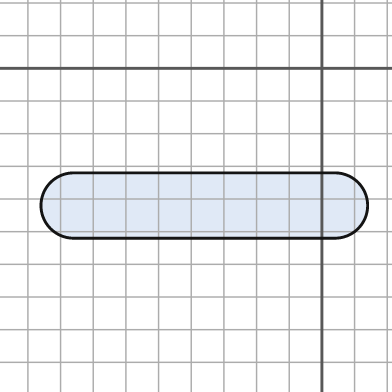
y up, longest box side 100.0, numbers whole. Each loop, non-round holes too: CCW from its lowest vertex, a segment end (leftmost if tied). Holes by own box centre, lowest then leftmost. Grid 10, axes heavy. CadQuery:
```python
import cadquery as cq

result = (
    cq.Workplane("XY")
    .moveTo(-76.0, -52.0)
    .lineTo(4.0, -52.0)
    .threePointArc((14.0, -42.0), (4.0, -32.0))
    .lineTo(-76.0, -32.0)
    .threePointArc((-86.0, -42.0), (-76.0, -52.0))
    .close()
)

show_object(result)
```